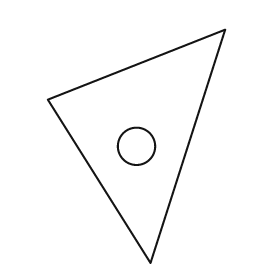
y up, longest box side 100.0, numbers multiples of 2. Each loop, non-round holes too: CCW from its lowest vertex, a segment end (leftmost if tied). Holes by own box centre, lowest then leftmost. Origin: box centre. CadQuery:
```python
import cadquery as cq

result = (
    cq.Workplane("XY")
    .moveTo(6.0, -50.0)
    .lineTo(38.0, 50.0)
    .lineTo(-38.0, 20.0)
    .close()
    .moveTo(0.0, 0.0)
    .circle(8.0)
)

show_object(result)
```